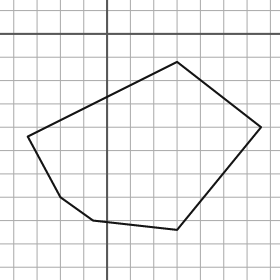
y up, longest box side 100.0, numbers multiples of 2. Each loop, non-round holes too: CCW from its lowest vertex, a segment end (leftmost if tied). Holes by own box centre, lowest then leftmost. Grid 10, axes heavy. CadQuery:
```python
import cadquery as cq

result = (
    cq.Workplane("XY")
    .moveTo(30.0, -84.0)
    .lineTo(66.0, -40.0)
    .lineTo(30.0, -12.0)
    .lineTo(-34.0, -44.0)
    .lineTo(-20.0, -70.0)
    .lineTo(-6.0, -80.0)
    .close()
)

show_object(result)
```